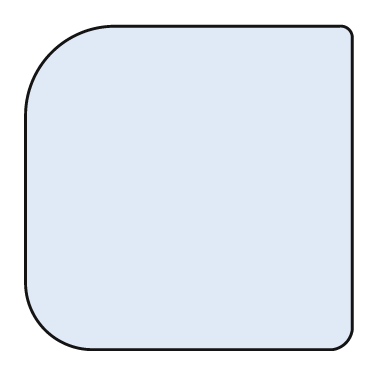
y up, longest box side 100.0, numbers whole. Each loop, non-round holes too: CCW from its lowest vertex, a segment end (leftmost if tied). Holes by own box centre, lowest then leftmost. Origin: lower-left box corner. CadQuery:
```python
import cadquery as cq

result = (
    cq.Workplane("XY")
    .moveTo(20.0, 0.0)
    .lineTo(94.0, 0.0)
    .threePointArc((98.0, 2.0), (100.0, 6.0))
    .lineTo(100.0, 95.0)
    .threePointArc((99.0, 98.0), (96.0, 99.0))
    .lineTo(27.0, 99.0)
    .threePointArc((8.0, 91.0), (0.0, 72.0))
    .lineTo(0.0, 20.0)
    .threePointArc((6.0, 6.0), (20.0, 0.0))
    .close()
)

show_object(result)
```